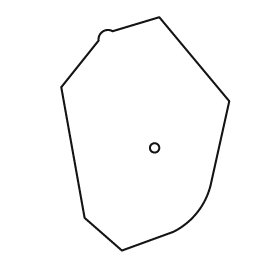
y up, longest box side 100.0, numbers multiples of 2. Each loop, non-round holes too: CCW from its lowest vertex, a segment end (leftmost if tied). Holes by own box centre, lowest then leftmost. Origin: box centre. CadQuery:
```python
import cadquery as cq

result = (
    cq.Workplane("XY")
    .moveTo(-10.0, -50.0)
    .lineTo(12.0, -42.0)
    .threePointArc((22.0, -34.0), (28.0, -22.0))
    .lineTo(36.0, 14.0)
    .lineTo(6.0, 50.0)
    .lineTo(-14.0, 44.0)
    .threePointArc((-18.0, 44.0), (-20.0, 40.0))
    .lineTo(-36.0, 20.0)
    .lineTo(-26.0, -36.0)
    .close()
    .moveTo(4.0, -6.0)
    .circle(2.0)
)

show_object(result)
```